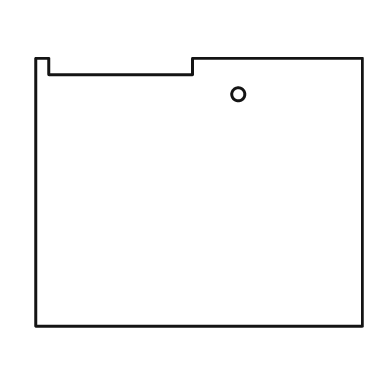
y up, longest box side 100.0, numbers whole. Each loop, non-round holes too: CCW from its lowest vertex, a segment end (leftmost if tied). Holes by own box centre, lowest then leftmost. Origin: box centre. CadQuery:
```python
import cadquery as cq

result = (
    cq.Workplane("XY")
    .moveTo(-50.0, -41.0)
    .lineTo(50.0, -41.0)
    .lineTo(50.0, 41.0)
    .lineTo(-2.0, 41.0)
    .lineTo(-2.0, 36.0)
    .lineTo(-46.0, 36.0)
    .lineTo(-46.0, 41.0)
    .lineTo(-50.0, 41.0)
    .close()
    .moveTo(12.0, 30.0)
    .circle(2.0)
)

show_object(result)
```